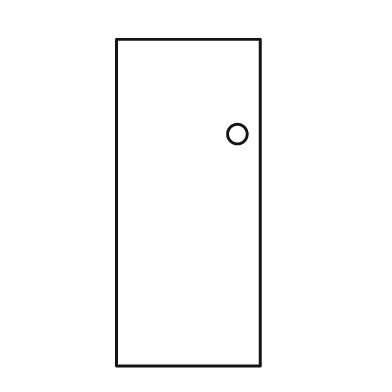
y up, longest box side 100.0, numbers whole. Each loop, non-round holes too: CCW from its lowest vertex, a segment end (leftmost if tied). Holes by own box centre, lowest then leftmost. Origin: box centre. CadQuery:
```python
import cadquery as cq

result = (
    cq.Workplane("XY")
    .moveTo(-22.0, -50.0)
    .lineTo(22.0, -50.0)
    .lineTo(22.0, 50.0)
    .lineTo(-22.0, 50.0)
    .close()
    .moveTo(15.0, 21.0)
    .circle(3.0)
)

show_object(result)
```